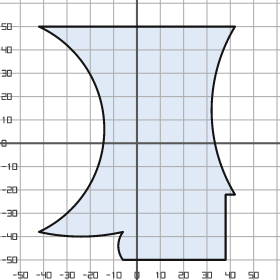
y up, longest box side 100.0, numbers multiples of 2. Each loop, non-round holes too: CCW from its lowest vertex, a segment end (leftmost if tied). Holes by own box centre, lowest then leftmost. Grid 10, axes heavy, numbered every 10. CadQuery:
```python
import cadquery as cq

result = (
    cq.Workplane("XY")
    .moveTo(-6.0, -50.0)
    .lineTo(38.0, -50.0)
    .lineTo(38.0, -22.0)
    .lineTo(42.0, -22.0)
    .threePointArc((32.0, 14.0), (42.0, 50.0))
    .lineTo(-42.0, 50.0)
    .threePointArc((-14.0, 6.0), (-42.0, -38.0))
    .threePointArc((-24.0, -40.0), (-6.0, -38.0))
    .threePointArc((-8.0, -44.0), (-6.0, -50.0))
    .close()
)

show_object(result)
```